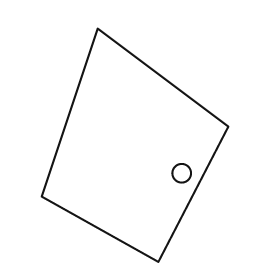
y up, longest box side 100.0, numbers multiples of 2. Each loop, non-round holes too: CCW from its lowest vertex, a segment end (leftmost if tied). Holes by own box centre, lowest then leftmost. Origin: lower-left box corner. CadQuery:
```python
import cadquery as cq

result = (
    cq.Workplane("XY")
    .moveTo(50.0, 0.0)
    .lineTo(80.0, 58.0)
    .lineTo(24.0, 100.0)
    .lineTo(0.0, 28.0)
    .close()
    .moveTo(60.0, 38.0)
    .circle(4.0)
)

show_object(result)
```